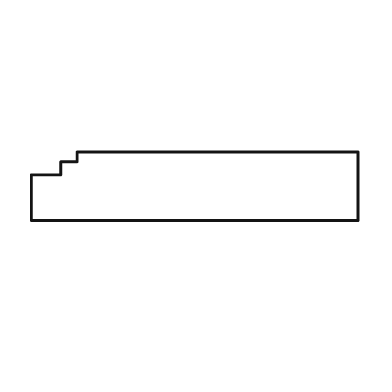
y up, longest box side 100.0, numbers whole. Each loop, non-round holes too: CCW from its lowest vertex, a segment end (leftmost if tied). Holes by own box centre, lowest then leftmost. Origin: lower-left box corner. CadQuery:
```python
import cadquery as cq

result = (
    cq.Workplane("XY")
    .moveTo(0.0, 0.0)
    .lineTo(100.0, 0.0)
    .lineTo(100.0, 21.0)
    .lineTo(14.0, 21.0)
    .lineTo(14.0, 18.0)
    .lineTo(9.0, 18.0)
    .lineTo(9.0, 14.0)
    .lineTo(0.0, 14.0)
    .close()
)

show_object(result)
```